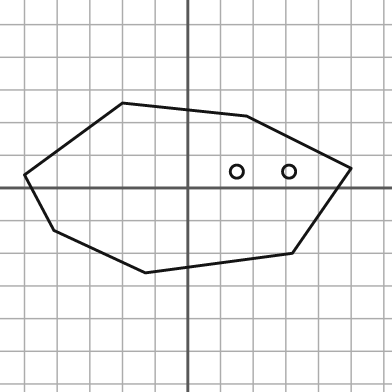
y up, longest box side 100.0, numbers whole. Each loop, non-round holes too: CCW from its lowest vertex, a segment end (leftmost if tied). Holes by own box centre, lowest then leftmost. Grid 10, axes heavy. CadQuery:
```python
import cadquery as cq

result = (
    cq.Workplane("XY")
    .moveTo(-13.0, -26.0)
    .lineTo(32.0, -20.0)
    .lineTo(50.0, 6.0)
    .lineTo(18.0, 22.0)
    .lineTo(-20.0, 26.0)
    .lineTo(-50.0, 4.0)
    .lineTo(-41.0, -13.0)
    .close()
    .moveTo(15.0, 5.0)
    .circle(2.0)
    .moveTo(31.0, 5.0)
    .circle(2.0)
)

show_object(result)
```